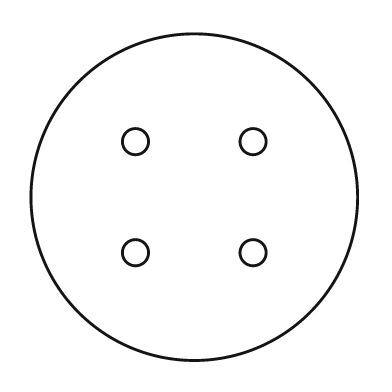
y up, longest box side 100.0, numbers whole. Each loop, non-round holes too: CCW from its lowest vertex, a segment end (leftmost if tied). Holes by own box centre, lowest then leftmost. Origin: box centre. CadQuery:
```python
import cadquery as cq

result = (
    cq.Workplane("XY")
    .moveTo(0.0, 0.0)
    .circle(50.0)
    .moveTo(-18.0, -17.0)
    .circle(4.0)
    .moveTo(18.0, -17.0)
    .circle(4.0)
    .moveTo(-18.0, 17.0)
    .circle(4.0)
    .moveTo(18.0, 17.0)
    .circle(4.0)
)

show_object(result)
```